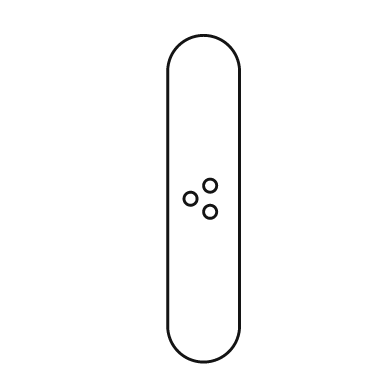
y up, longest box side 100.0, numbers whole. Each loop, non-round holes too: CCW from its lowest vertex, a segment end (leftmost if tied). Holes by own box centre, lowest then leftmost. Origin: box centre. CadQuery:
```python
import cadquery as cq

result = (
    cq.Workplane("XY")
    .moveTo(-11.0, -39.0)
    .threePointArc((0.0, -50.0), (11.0, -39.0))
    .lineTo(11.0, 39.0)
    .threePointArc((0.0, 50.0), (-11.0, 39.0))
    .close()
    .moveTo(2.0, -4.0)
    .circle(2.0)
    .moveTo(-4.0, 0.0)
    .circle(2.0)
    .moveTo(2.0, 4.0)
    .circle(2.0)
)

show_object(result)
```